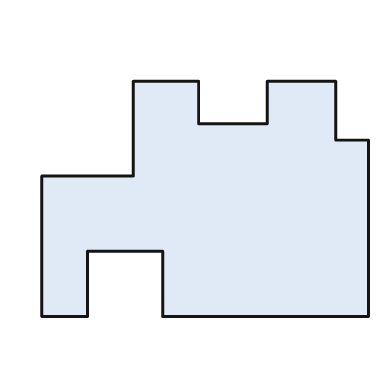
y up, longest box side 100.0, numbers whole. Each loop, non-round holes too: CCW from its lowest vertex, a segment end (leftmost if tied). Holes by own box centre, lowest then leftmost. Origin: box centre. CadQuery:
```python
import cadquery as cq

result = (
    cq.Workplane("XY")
    .moveTo(-50.0, -36.0)
    .lineTo(-36.0, -36.0)
    .lineTo(-36.0, -16.0)
    .lineTo(-13.0, -16.0)
    .lineTo(-13.0, -36.0)
    .lineTo(50.0, -36.0)
    .lineTo(50.0, 18.0)
    .lineTo(40.0, 18.0)
    .lineTo(40.0, 36.0)
    .lineTo(19.0, 36.0)
    .lineTo(19.0, 23.0)
    .lineTo(-2.0, 23.0)
    .lineTo(-2.0, 36.0)
    .lineTo(-22.0, 36.0)
    .lineTo(-22.0, 7.0)
    .lineTo(-50.0, 7.0)
    .close()
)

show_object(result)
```